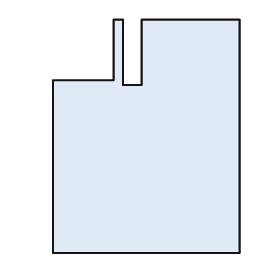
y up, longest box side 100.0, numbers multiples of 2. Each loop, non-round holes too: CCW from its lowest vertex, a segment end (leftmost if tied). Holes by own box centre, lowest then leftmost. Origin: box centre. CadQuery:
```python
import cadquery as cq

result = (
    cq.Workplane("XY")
    .moveTo(-40.0, -50.0)
    .lineTo(40.0, -50.0)
    .lineTo(40.0, 50.0)
    .lineTo(-2.0, 50.0)
    .lineTo(-2.0, 22.0)
    .lineTo(-10.0, 22.0)
    .lineTo(-10.0, 50.0)
    .lineTo(-14.0, 50.0)
    .lineTo(-14.0, 24.0)
    .lineTo(-40.0, 24.0)
    .close()
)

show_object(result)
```